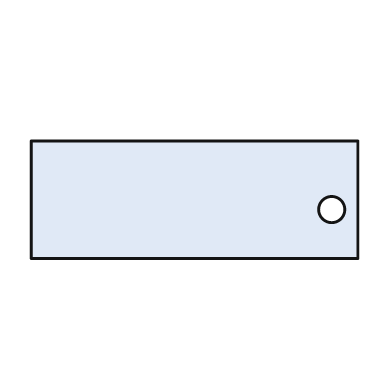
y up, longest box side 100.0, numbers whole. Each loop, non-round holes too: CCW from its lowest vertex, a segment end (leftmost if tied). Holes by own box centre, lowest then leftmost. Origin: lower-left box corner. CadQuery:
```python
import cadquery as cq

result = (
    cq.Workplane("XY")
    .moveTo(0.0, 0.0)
    .lineTo(100.0, 0.0)
    .lineTo(100.0, 36.0)
    .lineTo(0.0, 36.0)
    .close()
    .moveTo(92.0, 15.0)
    .circle(4.0)
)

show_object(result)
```